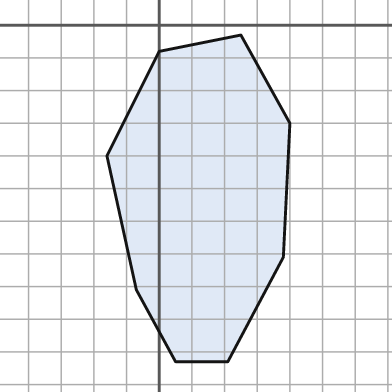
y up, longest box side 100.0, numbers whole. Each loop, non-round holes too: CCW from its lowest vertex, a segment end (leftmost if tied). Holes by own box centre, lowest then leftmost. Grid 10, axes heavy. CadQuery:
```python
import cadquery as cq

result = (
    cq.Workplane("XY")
    .moveTo(5.0, -103.0)
    .lineTo(21.0, -103.0)
    .lineTo(38.0, -71.0)
    .lineTo(40.0, -30.0)
    .lineTo(25.0, -3.0)
    .lineTo(0.0, -8.0)
    .lineTo(-16.0, -40.0)
    .lineTo(-7.0, -81.0)
    .close()
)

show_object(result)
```